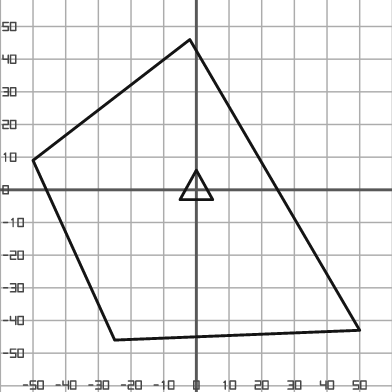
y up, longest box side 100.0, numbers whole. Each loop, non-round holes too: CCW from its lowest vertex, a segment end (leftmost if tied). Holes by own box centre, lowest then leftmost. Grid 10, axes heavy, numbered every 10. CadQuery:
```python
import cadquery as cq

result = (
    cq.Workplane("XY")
    .moveTo(-25.0, -46.0)
    .lineTo(50.0, -43.0)
    .lineTo(-2.0, 46.0)
    .lineTo(-50.0, 9.0)
    .close()
    .moveTo(-5.0, -3.0)
    .lineTo(5.0, -3.0)
    .lineTo(0.0, 6.0)
    .close()
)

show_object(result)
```